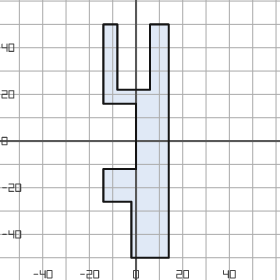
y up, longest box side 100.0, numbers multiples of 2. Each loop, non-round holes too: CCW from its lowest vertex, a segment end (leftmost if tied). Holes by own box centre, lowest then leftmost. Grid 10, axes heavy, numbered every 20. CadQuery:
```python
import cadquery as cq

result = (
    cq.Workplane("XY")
    .moveTo(-2.0, -50.0)
    .lineTo(14.0, -50.0)
    .lineTo(14.0, 50.0)
    .lineTo(6.0, 50.0)
    .lineTo(6.0, 22.0)
    .lineTo(-8.0, 22.0)
    .lineTo(-8.0, 50.0)
    .lineTo(-14.0, 50.0)
    .lineTo(-14.0, 16.0)
    .lineTo(0.0, 16.0)
    .lineTo(0.0, -12.0)
    .lineTo(-14.0, -12.0)
    .lineTo(-14.0, -26.0)
    .lineTo(-2.0, -26.0)
    .close()
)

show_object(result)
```